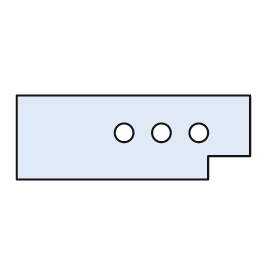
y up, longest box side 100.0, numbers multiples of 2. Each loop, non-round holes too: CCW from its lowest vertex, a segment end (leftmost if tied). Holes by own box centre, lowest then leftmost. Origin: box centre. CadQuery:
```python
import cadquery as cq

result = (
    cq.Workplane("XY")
    .moveTo(-50.0, -18.0)
    .lineTo(32.0, -18.0)
    .lineTo(32.0, -8.0)
    .lineTo(50.0, -8.0)
    .lineTo(50.0, 18.0)
    .lineTo(-50.0, 18.0)
    .close()
    .moveTo(-4.0, 2.0)
    .circle(4.0)
    .moveTo(12.0, 2.0)
    .circle(4.0)
    .moveTo(28.0, 2.0)
    .circle(4.0)
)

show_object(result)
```